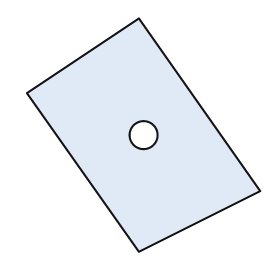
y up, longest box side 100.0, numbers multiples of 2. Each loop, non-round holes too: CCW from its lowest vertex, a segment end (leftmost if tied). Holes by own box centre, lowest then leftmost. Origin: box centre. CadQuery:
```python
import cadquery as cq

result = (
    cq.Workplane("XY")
    .moveTo(-2.0, -50.0)
    .lineTo(50.0, -24.0)
    .lineTo(-2.0, 50.0)
    .lineTo(-50.0, 18.0)
    .close()
    .moveTo(0.0, 0.0)
    .circle(6.0)
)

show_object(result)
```